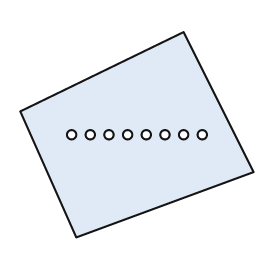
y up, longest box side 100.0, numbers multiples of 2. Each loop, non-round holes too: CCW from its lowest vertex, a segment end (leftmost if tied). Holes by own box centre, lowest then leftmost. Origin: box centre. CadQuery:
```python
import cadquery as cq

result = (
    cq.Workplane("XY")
    .moveTo(-26.0, -44.0)
    .lineTo(50.0, -16.0)
    .lineTo(20.0, 44.0)
    .lineTo(-50.0, 10.0)
    .close()
    .moveTo(-28.0, 0.0)
    .circle(2.0)
    .moveTo(-20.0, 0.0)
    .circle(2.0)
    .moveTo(-12.0, 0.0)
    .circle(2.0)
    .moveTo(-4.0, 0.0)
    .circle(2.0)
    .moveTo(4.0, 0.0)
    .circle(2.0)
    .moveTo(12.0, 0.0)
    .circle(2.0)
    .moveTo(20.0, 0.0)
    .circle(2.0)
    .moveTo(28.0, 0.0)
    .circle(2.0)
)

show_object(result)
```